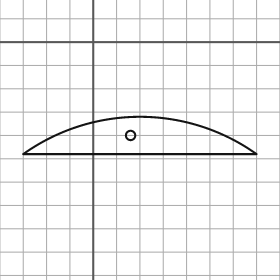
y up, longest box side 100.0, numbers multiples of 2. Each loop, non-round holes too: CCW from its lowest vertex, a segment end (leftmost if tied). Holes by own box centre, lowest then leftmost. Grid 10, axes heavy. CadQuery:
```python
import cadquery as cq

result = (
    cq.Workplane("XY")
    .moveTo(-30.0, -48.0)
    .lineTo(70.0, -48.0)
    .threePointArc((20.0, -32.0), (-30.0, -48.0))
    .close()
    .moveTo(16.0, -40.0)
    .circle(2.0)
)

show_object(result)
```